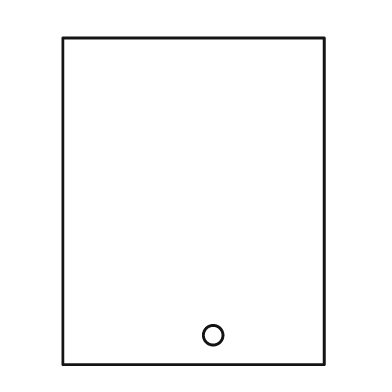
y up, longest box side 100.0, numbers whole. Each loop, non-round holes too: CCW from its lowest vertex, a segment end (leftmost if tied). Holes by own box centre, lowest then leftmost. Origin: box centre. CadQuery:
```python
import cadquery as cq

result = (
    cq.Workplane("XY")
    .moveTo(-40.0, -50.0)
    .lineTo(40.0, -50.0)
    .lineTo(40.0, 50.0)
    .lineTo(-40.0, 50.0)
    .close()
    .moveTo(6.0, -41.0)
    .circle(3.0)
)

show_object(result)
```